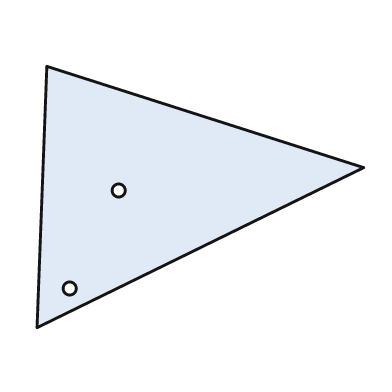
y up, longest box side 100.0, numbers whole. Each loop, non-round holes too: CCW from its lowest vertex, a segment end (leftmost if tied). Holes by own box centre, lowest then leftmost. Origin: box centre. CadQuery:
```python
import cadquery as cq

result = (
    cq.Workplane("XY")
    .moveTo(-50.0, -40.0)
    .lineTo(50.0, 9.0)
    .lineTo(-47.0, 40.0)
    .close()
    .moveTo(-40.0, -28.0)
    .circle(2.0)
    .moveTo(-25.0, 2.0)
    .circle(2.0)
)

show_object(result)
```